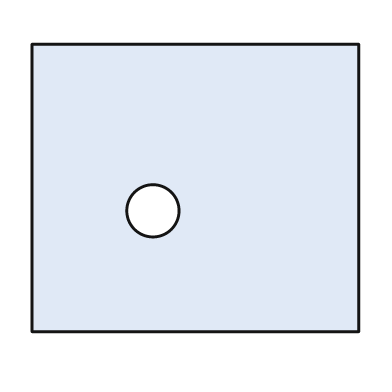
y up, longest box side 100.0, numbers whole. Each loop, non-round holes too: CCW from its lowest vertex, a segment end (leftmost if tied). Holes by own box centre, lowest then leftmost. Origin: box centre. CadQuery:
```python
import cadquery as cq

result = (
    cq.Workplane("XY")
    .moveTo(-50.0, -44.0)
    .lineTo(50.0, -44.0)
    .lineTo(50.0, 44.0)
    .lineTo(-50.0, 44.0)
    .close()
    .moveTo(-13.0, -7.0)
    .circle(8.0)
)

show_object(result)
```